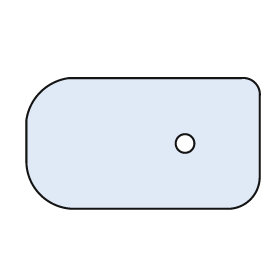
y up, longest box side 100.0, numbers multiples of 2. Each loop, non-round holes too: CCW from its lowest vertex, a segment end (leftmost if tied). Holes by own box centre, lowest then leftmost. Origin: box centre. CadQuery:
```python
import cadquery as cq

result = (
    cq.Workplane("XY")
    .moveTo(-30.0, -28.0)
    .lineTo(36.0, -28.0)
    .threePointArc((46.0, -24.0), (50.0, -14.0))
    .lineTo(50.0, 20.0)
    .threePointArc((48.0, 26.0), (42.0, 28.0))
    .lineTo(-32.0, 28.0)
    .threePointArc((-44.0, 22.0), (-50.0, 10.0))
    .lineTo(-50.0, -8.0)
    .threePointArc((-44.0, -22.0), (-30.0, -28.0))
    .close()
    .moveTo(18.0, 0.0)
    .circle(4.0)
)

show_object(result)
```